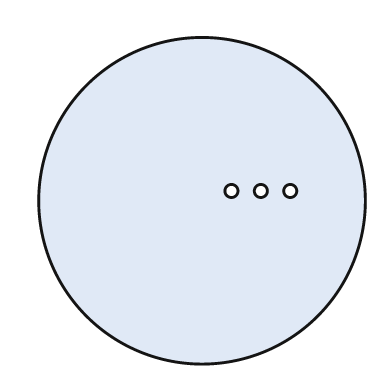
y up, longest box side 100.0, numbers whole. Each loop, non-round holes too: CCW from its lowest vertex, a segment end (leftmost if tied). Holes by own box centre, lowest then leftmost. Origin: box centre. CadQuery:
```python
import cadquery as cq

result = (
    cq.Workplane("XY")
    .moveTo(0.0, 0.0)
    .circle(50.0)
    .moveTo(9.0, 3.0)
    .circle(2.0)
    .moveTo(18.0, 3.0)
    .circle(2.0)
    .moveTo(27.0, 3.0)
    .circle(2.0)
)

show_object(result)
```